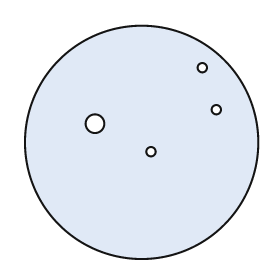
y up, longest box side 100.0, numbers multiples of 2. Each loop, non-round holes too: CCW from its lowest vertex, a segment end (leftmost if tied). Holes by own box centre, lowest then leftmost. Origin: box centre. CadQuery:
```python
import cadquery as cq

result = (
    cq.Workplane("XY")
    .moveTo(0.0, 0.0)
    .circle(50.0)
    .moveTo(4.0, -4.0)
    .circle(2.0)
    .moveTo(-20.0, 8.0)
    .circle(4.0)
    .moveTo(32.0, 14.0)
    .circle(2.0)
    .moveTo(26.0, 32.0)
    .circle(2.0)
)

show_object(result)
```